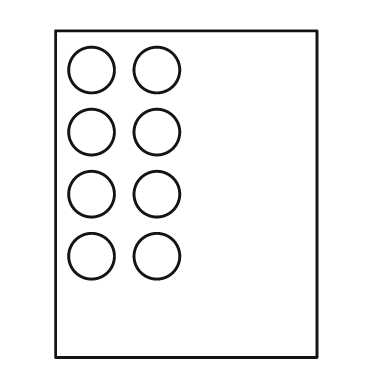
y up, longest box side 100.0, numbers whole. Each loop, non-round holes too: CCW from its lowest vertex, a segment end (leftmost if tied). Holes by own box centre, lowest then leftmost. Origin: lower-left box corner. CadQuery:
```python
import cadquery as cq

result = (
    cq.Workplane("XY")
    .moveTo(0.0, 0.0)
    .lineTo(80.0, 0.0)
    .lineTo(80.0, 100.0)
    .lineTo(0.0, 100.0)
    .close()
    .moveTo(11.0, 31.0)
    .circle(7.0)
    .moveTo(31.0, 31.0)
    .circle(7.0)
    .moveTo(11.0, 50.0)
    .circle(7.0)
    .moveTo(31.0, 50.0)
    .circle(7.0)
    .moveTo(11.0, 69.0)
    .circle(7.0)
    .moveTo(31.0, 69.0)
    .circle(7.0)
    .moveTo(11.0, 88.0)
    .circle(7.0)
    .moveTo(31.0, 88.0)
    .circle(7.0)
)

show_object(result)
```